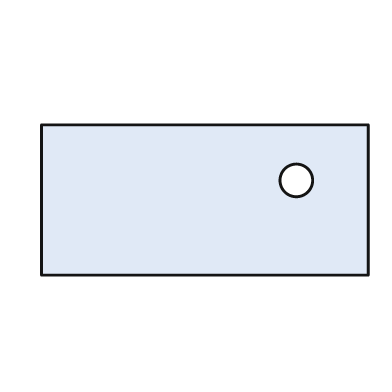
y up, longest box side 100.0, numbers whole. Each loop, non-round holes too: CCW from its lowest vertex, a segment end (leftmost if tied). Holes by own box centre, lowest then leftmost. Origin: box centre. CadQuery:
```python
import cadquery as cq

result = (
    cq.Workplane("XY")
    .moveTo(-50.0, -23.0)
    .lineTo(50.0, -23.0)
    .lineTo(50.0, 23.0)
    .lineTo(-50.0, 23.0)
    .close()
    .moveTo(28.0, 6.0)
    .circle(5.0)
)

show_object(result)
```